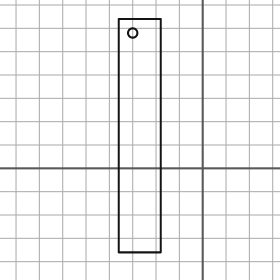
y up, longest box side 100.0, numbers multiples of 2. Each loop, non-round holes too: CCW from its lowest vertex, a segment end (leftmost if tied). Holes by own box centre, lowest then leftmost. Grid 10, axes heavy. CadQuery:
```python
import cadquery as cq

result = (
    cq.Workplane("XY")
    .moveTo(-36.0, -36.0)
    .lineTo(-18.0, -36.0)
    .lineTo(-18.0, 64.0)
    .lineTo(-36.0, 64.0)
    .close()
    .moveTo(-30.0, 58.0)
    .circle(2.0)
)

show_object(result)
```